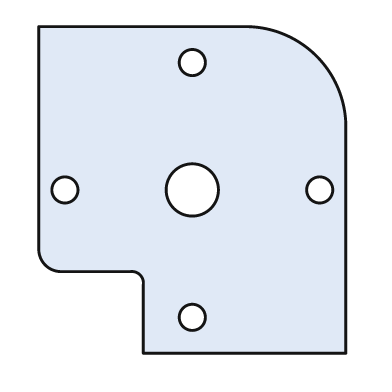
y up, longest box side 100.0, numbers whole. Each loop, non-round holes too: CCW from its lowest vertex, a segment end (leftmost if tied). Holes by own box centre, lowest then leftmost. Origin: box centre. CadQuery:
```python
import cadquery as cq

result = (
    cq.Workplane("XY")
    .moveTo(-15.0, -50.0)
    .lineTo(47.0, -50.0)
    .lineTo(47.0, 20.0)
    .threePointArc((38.0, 41.0), (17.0, 50.0))
    .lineTo(-47.0, 50.0)
    .lineTo(-47.0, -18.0)
    .threePointArc((-45.0, -23.0), (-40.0, -25.0))
    .lineTo(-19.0, -25.0)
    .threePointArc((-16.0, -26.0), (-15.0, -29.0))
    .close()
    .moveTo(0.0, -39.0)
    .circle(4.0)
    .moveTo(-39.0, 0.0)
    .circle(4.0)
    .moveTo(0.0, 0.0)
    .circle(8.0)
    .moveTo(39.0, 0.0)
    .circle(4.0)
    .moveTo(0.0, 39.0)
    .circle(4.0)
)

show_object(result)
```